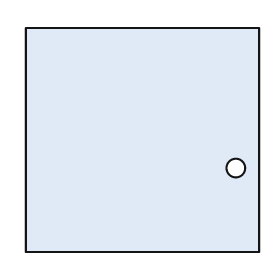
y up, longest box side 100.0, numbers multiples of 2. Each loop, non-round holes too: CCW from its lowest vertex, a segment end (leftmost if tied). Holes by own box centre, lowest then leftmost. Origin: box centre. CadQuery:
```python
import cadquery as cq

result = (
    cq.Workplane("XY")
    .moveTo(-50.0, -48.0)
    .lineTo(50.0, -48.0)
    .lineTo(50.0, 48.0)
    .lineTo(-50.0, 48.0)
    .close()
    .moveTo(40.0, -12.0)
    .circle(4.0)
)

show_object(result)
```